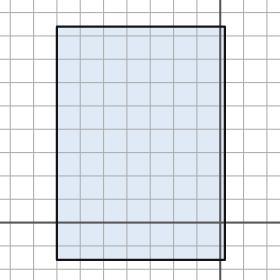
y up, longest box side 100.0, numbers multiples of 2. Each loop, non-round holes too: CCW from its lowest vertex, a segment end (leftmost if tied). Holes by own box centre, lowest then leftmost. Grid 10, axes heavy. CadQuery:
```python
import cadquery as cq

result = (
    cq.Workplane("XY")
    .moveTo(-70.0, -16.0)
    .lineTo(2.0, -16.0)
    .lineTo(2.0, 84.0)
    .lineTo(-70.0, 84.0)
    .close()
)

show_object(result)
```